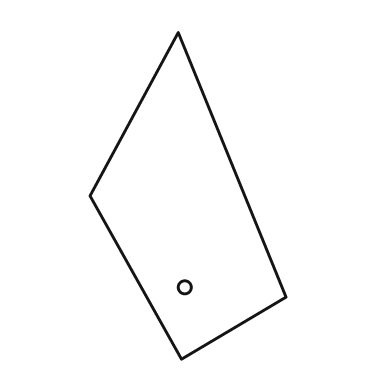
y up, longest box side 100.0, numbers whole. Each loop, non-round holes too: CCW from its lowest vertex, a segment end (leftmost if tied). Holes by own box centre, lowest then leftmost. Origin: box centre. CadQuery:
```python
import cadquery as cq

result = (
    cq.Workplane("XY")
    .moveTo(-2.0, -50.0)
    .lineTo(30.0, -31.0)
    .lineTo(-3.0, 50.0)
    .lineTo(-30.0, 0.0)
    .close()
    .moveTo(-1.0, -28.0)
    .circle(2.0)
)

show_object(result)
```